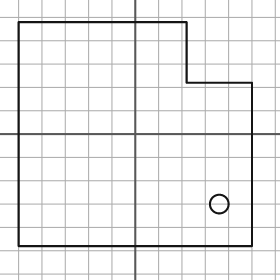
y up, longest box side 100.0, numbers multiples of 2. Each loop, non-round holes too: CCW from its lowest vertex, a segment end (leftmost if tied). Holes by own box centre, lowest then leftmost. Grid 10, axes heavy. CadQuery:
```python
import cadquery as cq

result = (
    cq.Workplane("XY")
    .moveTo(-50.0, -48.0)
    .lineTo(50.0, -48.0)
    .lineTo(50.0, 22.0)
    .lineTo(22.0, 22.0)
    .lineTo(22.0, 48.0)
    .lineTo(-50.0, 48.0)
    .close()
    .moveTo(36.0, -30.0)
    .circle(4.0)
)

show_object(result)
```